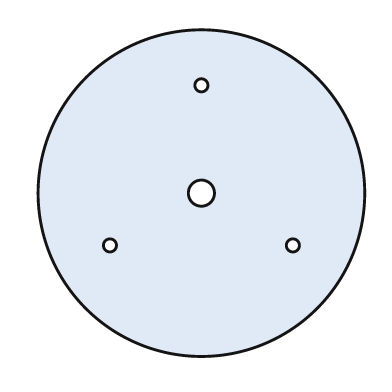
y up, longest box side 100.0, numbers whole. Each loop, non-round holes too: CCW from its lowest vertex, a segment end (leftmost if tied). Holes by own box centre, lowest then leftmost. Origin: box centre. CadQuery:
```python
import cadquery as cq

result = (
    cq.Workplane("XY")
    .moveTo(0.0, 0.0)
    .circle(50.0)
    .moveTo(-28.0, -16.0)
    .circle(2.0)
    .moveTo(28.0, -16.0)
    .circle(2.0)
    .moveTo(0.0, 0.0)
    .circle(4.0)
    .moveTo(0.0, 33.0)
    .circle(2.0)
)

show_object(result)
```